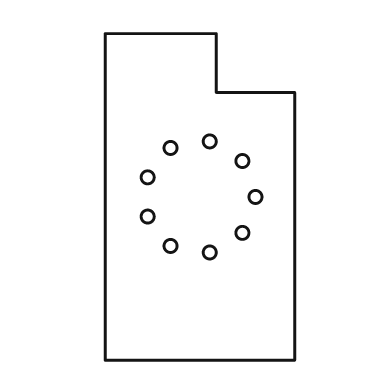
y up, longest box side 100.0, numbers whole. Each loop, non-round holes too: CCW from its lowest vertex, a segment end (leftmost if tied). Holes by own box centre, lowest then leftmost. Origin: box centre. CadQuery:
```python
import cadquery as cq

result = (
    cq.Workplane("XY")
    .moveTo(-29.0, -50.0)
    .lineTo(29.0, -50.0)
    .lineTo(29.0, 32.0)
    .lineTo(5.0, 32.0)
    .lineTo(5.0, 50.0)
    .lineTo(-29.0, 50.0)
    .close()
    .moveTo(3.0, -17.0)
    .circle(2.0)
    .moveTo(-9.0, -15.0)
    .circle(2.0)
    .moveTo(13.0, -11.0)
    .circle(2.0)
    .moveTo(-16.0, -6.0)
    .circle(2.0)
    .moveTo(17.0, 0.0)
    .circle(2.0)
    .moveTo(-16.0, 6.0)
    .circle(2.0)
    .moveTo(13.0, 11.0)
    .circle(2.0)
    .moveTo(-9.0, 15.0)
    .circle(2.0)
    .moveTo(3.0, 17.0)
    .circle(2.0)
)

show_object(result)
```